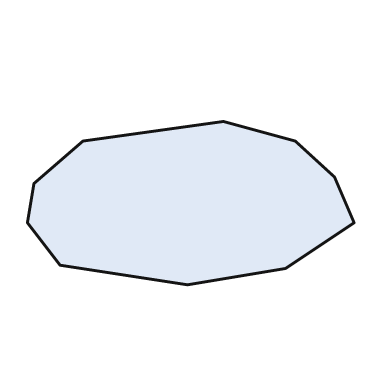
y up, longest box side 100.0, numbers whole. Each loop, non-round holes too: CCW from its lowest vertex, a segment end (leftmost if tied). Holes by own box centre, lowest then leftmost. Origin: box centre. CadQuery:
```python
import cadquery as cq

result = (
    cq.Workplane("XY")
    .moveTo(-1.0, -25.0)
    .lineTo(29.0, -20.0)
    .lineTo(50.0, -6.0)
    .lineTo(44.0, 8.0)
    .lineTo(32.0, 19.0)
    .lineTo(10.0, 25.0)
    .lineTo(-33.0, 19.0)
    .lineTo(-48.0, 6.0)
    .lineTo(-50.0, -6.0)
    .lineTo(-40.0, -19.0)
    .close()
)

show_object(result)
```